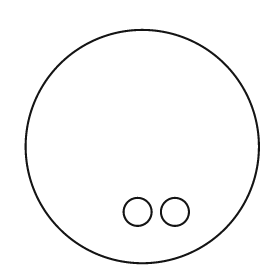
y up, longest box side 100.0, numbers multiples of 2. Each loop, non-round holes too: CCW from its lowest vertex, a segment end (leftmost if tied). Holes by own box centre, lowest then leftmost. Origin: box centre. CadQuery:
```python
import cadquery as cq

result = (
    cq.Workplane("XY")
    .moveTo(0.0, 0.0)
    .circle(50.0)
    .moveTo(-2.0, -28.0)
    .circle(6.0)
    .moveTo(14.0, -28.0)
    .circle(6.0)
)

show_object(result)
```